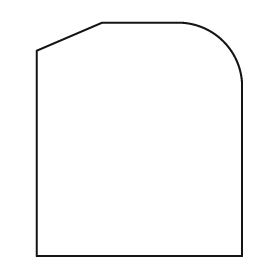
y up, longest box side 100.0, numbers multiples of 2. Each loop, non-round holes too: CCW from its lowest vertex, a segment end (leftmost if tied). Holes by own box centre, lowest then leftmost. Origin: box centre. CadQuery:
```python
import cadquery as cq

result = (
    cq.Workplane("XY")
    .moveTo(-44.0, -50.0)
    .lineTo(44.0, -50.0)
    .lineTo(44.0, 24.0)
    .threePointArc((36.0, 42.0), (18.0, 50.0))
    .lineTo(-16.0, 50.0)
    .lineTo(-44.0, 38.0)
    .close()
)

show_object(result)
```